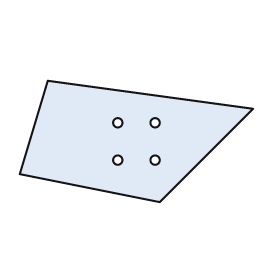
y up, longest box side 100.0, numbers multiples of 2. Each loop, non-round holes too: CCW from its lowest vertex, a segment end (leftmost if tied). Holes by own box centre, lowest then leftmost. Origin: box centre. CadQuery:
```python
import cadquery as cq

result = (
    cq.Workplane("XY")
    .moveTo(10.0, -26.0)
    .lineTo(50.0, 14.0)
    .lineTo(-38.0, 26.0)
    .lineTo(-50.0, -14.0)
    .close()
    .moveTo(-8.0, -8.0)
    .circle(2.0)
    .moveTo(8.0, -8.0)
    .circle(2.0)
    .moveTo(-8.0, 8.0)
    .circle(2.0)
    .moveTo(8.0, 8.0)
    .circle(2.0)
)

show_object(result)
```